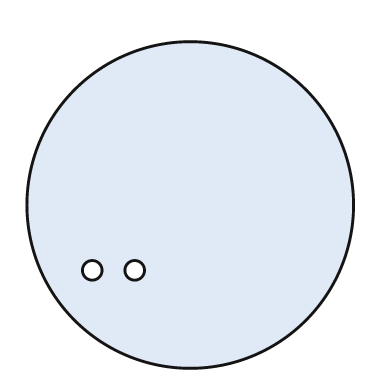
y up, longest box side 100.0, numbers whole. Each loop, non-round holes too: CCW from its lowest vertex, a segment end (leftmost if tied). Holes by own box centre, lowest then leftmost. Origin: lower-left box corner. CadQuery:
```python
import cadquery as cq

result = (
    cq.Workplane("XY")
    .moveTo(50.0, 50.0)
    .circle(50.0)
    .moveTo(20.0, 30.0)
    .circle(3.0)
    .moveTo(33.0, 30.0)
    .circle(3.0)
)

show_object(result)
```